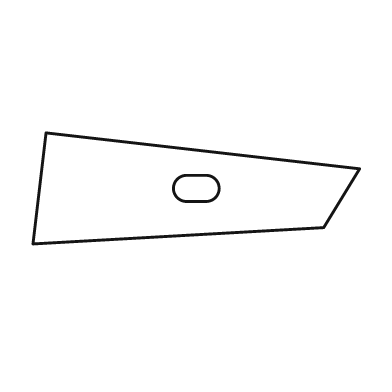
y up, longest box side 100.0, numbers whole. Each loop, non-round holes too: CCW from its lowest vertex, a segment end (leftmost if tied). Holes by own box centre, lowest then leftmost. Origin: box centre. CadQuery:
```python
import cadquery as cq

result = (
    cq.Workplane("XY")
    .moveTo(-50.0, -17.0)
    .lineTo(39.0, -12.0)
    .lineTo(50.0, 6.0)
    .lineTo(-46.0, 17.0)
    .close()
    .moveTo(-3.0, -4.0)
    .lineTo(3.0, -4.0)
    .threePointArc((7.0, 0.0), (3.0, 4.0))
    .lineTo(-3.0, 4.0)
    .threePointArc((-7.0, 0.0), (-3.0, -4.0))
    .close()
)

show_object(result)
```